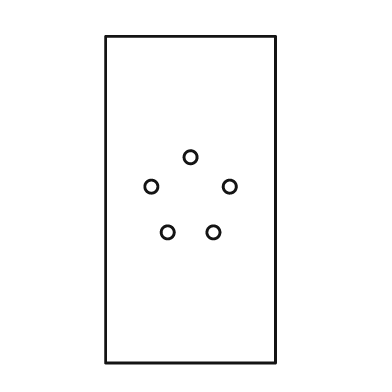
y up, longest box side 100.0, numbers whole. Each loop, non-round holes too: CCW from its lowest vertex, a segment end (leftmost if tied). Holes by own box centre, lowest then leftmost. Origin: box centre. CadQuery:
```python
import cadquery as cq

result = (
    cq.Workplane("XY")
    .moveTo(-26.0, -50.0)
    .lineTo(26.0, -50.0)
    .lineTo(26.0, 50.0)
    .lineTo(-26.0, 50.0)
    .close()
    .moveTo(-7.0, -10.0)
    .circle(2.0)
    .moveTo(7.0, -10.0)
    .circle(2.0)
    .moveTo(-12.0, 4.0)
    .circle(2.0)
    .moveTo(12.0, 4.0)
    .circle(2.0)
    .moveTo(0.0, 13.0)
    .circle(2.0)
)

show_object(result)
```